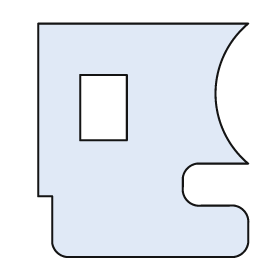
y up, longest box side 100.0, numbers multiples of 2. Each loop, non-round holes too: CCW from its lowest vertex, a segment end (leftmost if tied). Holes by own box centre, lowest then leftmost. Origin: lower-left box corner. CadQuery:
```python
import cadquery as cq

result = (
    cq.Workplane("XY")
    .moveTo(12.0, 0.0)
    .lineTo(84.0, 0.0)
    .threePointArc((88.0, 2.0), (90.0, 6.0))
    .lineTo(90.0, 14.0)
    .threePointArc((88.0, 20.0), (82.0, 22.0))
    .lineTo(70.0, 22.0)
    .threePointArc((64.0, 24.0), (62.0, 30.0))
    .lineTo(62.0, 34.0)
    .threePointArc((64.0, 38.0), (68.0, 40.0))
    .lineTo(90.0, 40.0)
    .threePointArc((76.0, 70.0), (90.0, 100.0))
    .lineTo(0.0, 100.0)
    .lineTo(0.0, 26.0)
    .lineTo(6.0, 26.0)
    .lineTo(6.0, 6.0)
    .threePointArc((8.0, 2.0), (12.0, 0.0))
    .close()
    .moveTo(18.0, 50.0)
    .lineTo(38.0, 50.0)
    .lineTo(38.0, 78.0)
    .lineTo(18.0, 78.0)
    .close()
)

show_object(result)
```